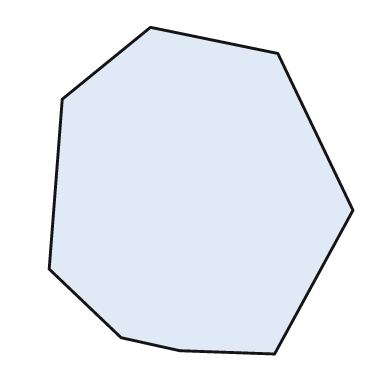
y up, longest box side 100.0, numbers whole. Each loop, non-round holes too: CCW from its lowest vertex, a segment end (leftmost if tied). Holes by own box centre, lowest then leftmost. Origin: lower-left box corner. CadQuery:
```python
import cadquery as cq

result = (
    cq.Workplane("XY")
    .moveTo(69.0, 0.0)
    .lineTo(93.0, 44.0)
    .lineTo(70.0, 92.0)
    .lineTo(31.0, 100.0)
    .lineTo(4.0, 78.0)
    .lineTo(0.0, 26.0)
    .lineTo(22.0, 5.0)
    .lineTo(40.0, 1.0)
    .close()
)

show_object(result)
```